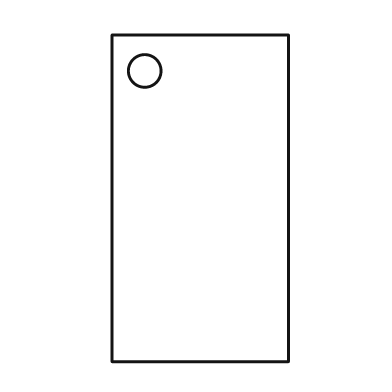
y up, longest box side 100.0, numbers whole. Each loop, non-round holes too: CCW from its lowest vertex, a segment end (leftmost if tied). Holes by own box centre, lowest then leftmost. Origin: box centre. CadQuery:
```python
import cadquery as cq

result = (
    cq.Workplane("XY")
    .moveTo(-27.0, -50.0)
    .lineTo(27.0, -50.0)
    .lineTo(27.0, 50.0)
    .lineTo(-27.0, 50.0)
    .close()
    .moveTo(-17.0, 39.0)
    .circle(5.0)
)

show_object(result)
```